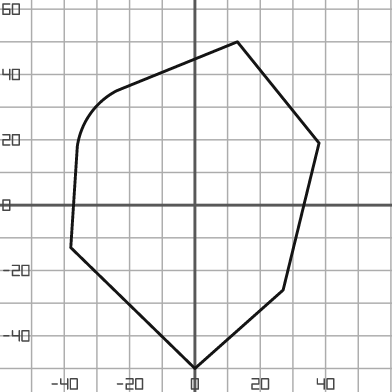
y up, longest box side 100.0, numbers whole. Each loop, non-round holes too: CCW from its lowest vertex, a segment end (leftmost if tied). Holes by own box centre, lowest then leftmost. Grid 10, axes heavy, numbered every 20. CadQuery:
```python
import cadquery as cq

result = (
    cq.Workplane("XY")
    .moveTo(0.0, -50.0)
    .lineTo(27.0, -26.0)
    .lineTo(38.0, 19.0)
    .lineTo(13.0, 50.0)
    .lineTo(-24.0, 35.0)
    .threePointArc((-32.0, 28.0), (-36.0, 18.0))
    .lineTo(-38.0, -13.0)
    .close()
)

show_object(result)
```